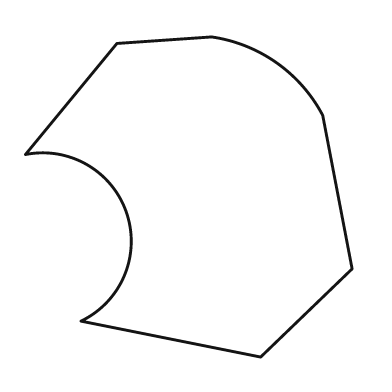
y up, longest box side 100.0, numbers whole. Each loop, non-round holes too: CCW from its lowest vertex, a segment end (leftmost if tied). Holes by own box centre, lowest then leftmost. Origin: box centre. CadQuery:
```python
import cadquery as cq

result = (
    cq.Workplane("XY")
    .moveTo(22.0, -49.0)
    .lineTo(50.0, -22.0)
    .lineTo(41.0, 25.0)
    .threePointArc((27.0, 41.0), (7.0, 49.0))
    .lineTo(-22.0, 47.0)
    .lineTo(-50.0, 13.0)
    .threePointArc((-19.0, -5.0), (-33.0, -38.0))
    .close()
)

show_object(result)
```